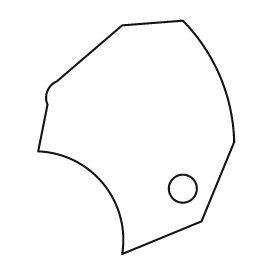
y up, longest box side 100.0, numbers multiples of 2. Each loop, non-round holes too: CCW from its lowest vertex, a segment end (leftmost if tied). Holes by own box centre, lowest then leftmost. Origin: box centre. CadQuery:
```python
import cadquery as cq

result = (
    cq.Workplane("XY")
    .moveTo(-6.0, -50.0)
    .lineTo(28.0, -36.0)
    .lineTo(42.0, -2.0)
    .threePointArc((36.0, 26.0), (20.0, 50.0))
    .lineTo(-6.0, 48.0)
    .lineTo(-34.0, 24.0)
    .threePointArc((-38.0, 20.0), (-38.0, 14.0))
    .lineTo(-42.0, -6.0)
    .threePointArc((-14.0, -20.0), (-6.0, -50.0))
    .close()
    .moveTo(20.0, -22.0)
    .circle(6.0)
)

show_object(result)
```